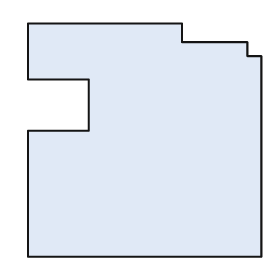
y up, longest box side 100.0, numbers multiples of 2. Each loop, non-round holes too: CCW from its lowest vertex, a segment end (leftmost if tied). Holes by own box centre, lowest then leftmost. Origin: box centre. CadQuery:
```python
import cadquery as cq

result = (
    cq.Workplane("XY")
    .moveTo(-50.0, -50.0)
    .lineTo(50.0, -50.0)
    .lineTo(50.0, 36.0)
    .lineTo(44.0, 36.0)
    .lineTo(44.0, 42.0)
    .lineTo(16.0, 42.0)
    .lineTo(16.0, 50.0)
    .lineTo(-50.0, 50.0)
    .lineTo(-50.0, 26.0)
    .lineTo(-24.0, 26.0)
    .lineTo(-24.0, 4.0)
    .lineTo(-50.0, 4.0)
    .close()
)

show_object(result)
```